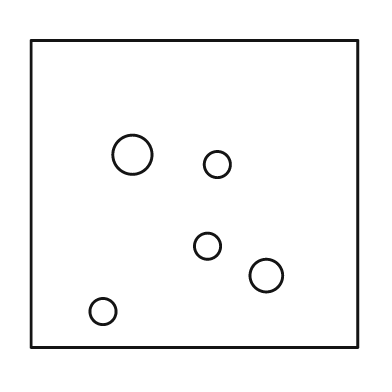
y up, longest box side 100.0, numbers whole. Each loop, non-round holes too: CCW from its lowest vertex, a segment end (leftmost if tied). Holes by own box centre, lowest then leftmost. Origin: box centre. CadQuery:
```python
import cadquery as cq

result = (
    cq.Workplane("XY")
    .moveTo(-50.0, -47.0)
    .lineTo(50.0, -47.0)
    .lineTo(50.0, 47.0)
    .lineTo(-50.0, 47.0)
    .close()
    .moveTo(-28.0, -36.0)
    .circle(4.0)
    .moveTo(22.0, -25.0)
    .circle(5.0)
    .moveTo(4.0, -16.0)
    .circle(4.0)
    .moveTo(7.0, 9.0)
    .circle(4.0)
    .moveTo(-19.0, 12.0)
    .circle(6.0)
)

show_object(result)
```